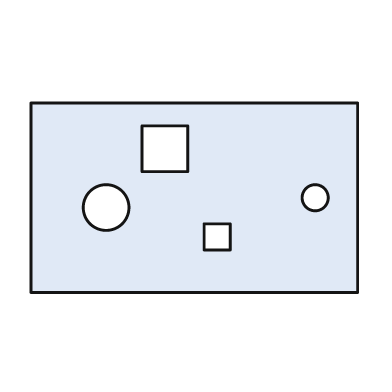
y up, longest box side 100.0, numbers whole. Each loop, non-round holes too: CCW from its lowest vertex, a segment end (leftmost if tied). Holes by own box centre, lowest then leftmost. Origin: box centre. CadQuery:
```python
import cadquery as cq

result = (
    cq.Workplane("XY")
    .moveTo(-50.0, -29.0)
    .lineTo(50.0, -29.0)
    .lineTo(50.0, 29.0)
    .lineTo(-50.0, 29.0)
    .close()
    .moveTo(3.0, -16.0)
    .lineTo(11.0, -16.0)
    .lineTo(11.0, -8.0)
    .lineTo(3.0, -8.0)
    .close()
    .moveTo(-27.0, -3.0)
    .circle(7.0)
    .moveTo(37.0, 0.0)
    .circle(4.0)
    .moveTo(-16.0, 8.0)
    .lineTo(-2.0, 8.0)
    .lineTo(-2.0, 22.0)
    .lineTo(-16.0, 22.0)
    .close()
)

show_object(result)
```